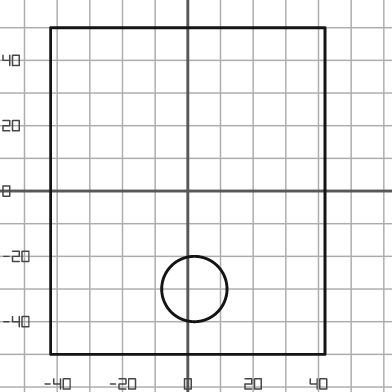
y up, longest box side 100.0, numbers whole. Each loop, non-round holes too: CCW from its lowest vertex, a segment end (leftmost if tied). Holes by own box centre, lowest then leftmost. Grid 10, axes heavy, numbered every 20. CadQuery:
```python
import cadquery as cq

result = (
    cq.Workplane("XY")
    .moveTo(-42.0, -50.0)
    .lineTo(42.0, -50.0)
    .lineTo(42.0, 50.0)
    .lineTo(-42.0, 50.0)
    .close()
    .moveTo(2.0, -30.0)
    .circle(10.0)
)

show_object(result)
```